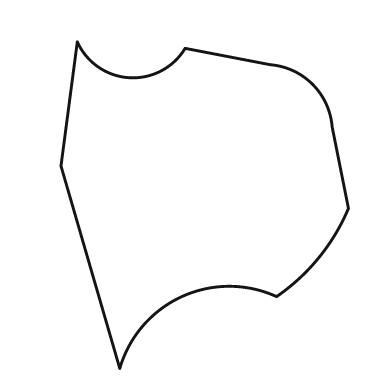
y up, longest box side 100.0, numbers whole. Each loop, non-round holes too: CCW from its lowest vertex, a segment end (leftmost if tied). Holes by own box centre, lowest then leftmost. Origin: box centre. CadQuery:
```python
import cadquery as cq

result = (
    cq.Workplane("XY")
    .moveTo(-26.0, -50.0)
    .threePointArc((-7.0, -28.0), (22.0, -28.0))
    .threePointArc((35.0, -16.0), (44.0, -1.0))
    .lineTo(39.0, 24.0)
    .threePointArc((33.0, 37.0), (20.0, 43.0))
    .lineTo(-6.0, 48.0)
    .threePointArc((-23.0, 39.0), (-39.0, 50.0))
    .lineTo(-44.0, 12.0)
    .close()
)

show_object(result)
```